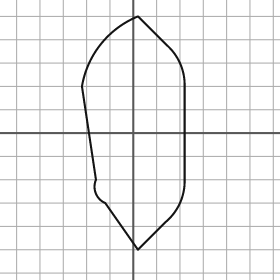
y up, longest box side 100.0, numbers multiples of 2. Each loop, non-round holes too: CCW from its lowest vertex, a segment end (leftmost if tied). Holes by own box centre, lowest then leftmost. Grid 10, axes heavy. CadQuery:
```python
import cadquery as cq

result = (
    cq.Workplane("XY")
    .moveTo(2.0, -50.0)
    .lineTo(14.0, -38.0)
    .threePointArc((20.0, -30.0), (22.0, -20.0))
    .lineTo(22.0, 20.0)
    .threePointArc((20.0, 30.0), (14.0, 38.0))
    .lineTo(2.0, 50.0)
    .threePointArc((-14.0, 38.0), (-22.0, 20.0))
    .lineTo(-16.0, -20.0)
    .threePointArc((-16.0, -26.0), (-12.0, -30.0))
    .close()
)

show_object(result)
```